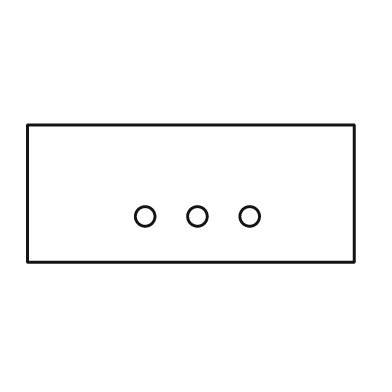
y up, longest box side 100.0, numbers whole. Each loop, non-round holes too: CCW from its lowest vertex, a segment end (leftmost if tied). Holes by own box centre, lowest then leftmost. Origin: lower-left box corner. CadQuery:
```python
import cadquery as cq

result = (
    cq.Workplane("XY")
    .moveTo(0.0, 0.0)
    .lineTo(100.0, 0.0)
    .lineTo(100.0, 42.0)
    .lineTo(0.0, 42.0)
    .close()
    .moveTo(36.0, 14.0)
    .circle(3.0)
    .moveTo(52.0, 14.0)
    .circle(3.0)
    .moveTo(68.0, 14.0)
    .circle(3.0)
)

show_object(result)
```